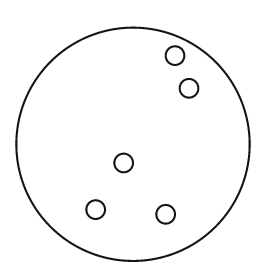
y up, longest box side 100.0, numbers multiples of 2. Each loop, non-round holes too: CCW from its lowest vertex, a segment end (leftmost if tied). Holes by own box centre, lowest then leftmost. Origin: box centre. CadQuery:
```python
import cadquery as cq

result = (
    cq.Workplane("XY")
    .moveTo(0.0, 0.0)
    .circle(50.0)
    .moveTo(14.0, -30.0)
    .circle(4.0)
    .moveTo(-16.0, -28.0)
    .circle(4.0)
    .moveTo(-4.0, -8.0)
    .circle(4.0)
    .moveTo(24.0, 24.0)
    .circle(4.0)
    .moveTo(18.0, 38.0)
    .circle(4.0)
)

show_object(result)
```